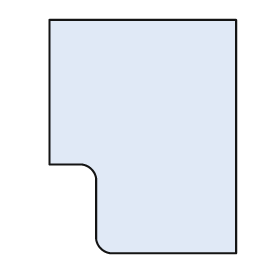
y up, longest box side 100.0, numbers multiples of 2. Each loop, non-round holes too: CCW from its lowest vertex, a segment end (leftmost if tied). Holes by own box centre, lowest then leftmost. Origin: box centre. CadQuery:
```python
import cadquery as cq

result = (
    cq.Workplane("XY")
    .moveTo(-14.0, -50.0)
    .lineTo(40.0, -50.0)
    .lineTo(40.0, 50.0)
    .lineTo(-40.0, 50.0)
    .lineTo(-40.0, -12.0)
    .lineTo(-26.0, -12.0)
    .threePointArc((-22.0, -14.0), (-20.0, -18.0))
    .lineTo(-20.0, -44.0)
    .threePointArc((-18.0, -48.0), (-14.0, -50.0))
    .close()
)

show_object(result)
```